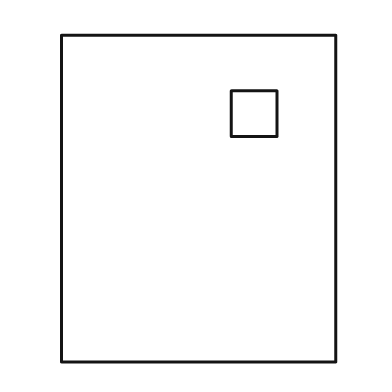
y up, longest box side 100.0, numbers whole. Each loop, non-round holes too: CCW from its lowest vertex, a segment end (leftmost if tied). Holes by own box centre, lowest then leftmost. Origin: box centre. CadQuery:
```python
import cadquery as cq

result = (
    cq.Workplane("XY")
    .moveTo(-42.0, -50.0)
    .lineTo(42.0, -50.0)
    .lineTo(42.0, 50.0)
    .lineTo(-42.0, 50.0)
    .close()
    .moveTo(10.0, 19.0)
    .lineTo(24.0, 19.0)
    .lineTo(24.0, 33.0)
    .lineTo(10.0, 33.0)
    .close()
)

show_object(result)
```